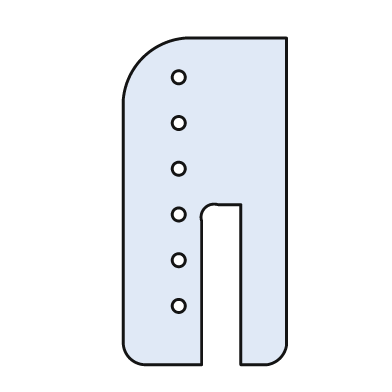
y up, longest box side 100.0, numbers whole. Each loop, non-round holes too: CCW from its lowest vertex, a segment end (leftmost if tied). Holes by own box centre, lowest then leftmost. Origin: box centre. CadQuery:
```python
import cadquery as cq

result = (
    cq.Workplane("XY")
    .moveTo(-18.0, -50.0)
    .lineTo(-1.0, -50.0)
    .lineTo(-1.0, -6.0)
    .threePointArc((0.0, -2.0), (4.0, -1.0))
    .lineTo(11.0, -1.0)
    .lineTo(11.0, -50.0)
    .lineTo(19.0, -50.0)
    .threePointArc((23.0, -48.0), (25.0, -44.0))
    .lineTo(25.0, 50.0)
    .lineTo(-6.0, 50.0)
    .threePointArc((-19.0, 44.0), (-25.0, 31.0))
    .lineTo(-25.0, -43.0)
    .threePointArc((-23.0, -48.0), (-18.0, -50.0))
    .close()
    .moveTo(-8.0, -32.0)
    .circle(2.0)
    .moveTo(-8.0, -18.0)
    .circle(2.0)
    .moveTo(-8.0, -4.0)
    .circle(2.0)
    .moveTo(-8.0, 10.0)
    .circle(2.0)
    .moveTo(-8.0, 24.0)
    .circle(2.0)
    .moveTo(-8.0, 38.0)
    .circle(2.0)
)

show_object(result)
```